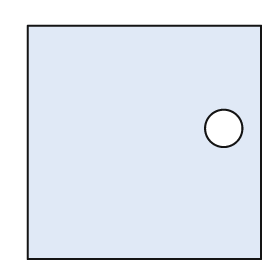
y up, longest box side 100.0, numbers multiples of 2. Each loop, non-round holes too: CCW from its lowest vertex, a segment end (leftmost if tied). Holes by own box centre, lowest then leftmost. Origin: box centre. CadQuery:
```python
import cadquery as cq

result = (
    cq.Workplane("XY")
    .moveTo(-50.0, -50.0)
    .lineTo(50.0, -50.0)
    .lineTo(50.0, 50.0)
    .lineTo(-50.0, 50.0)
    .close()
    .moveTo(34.0, 6.0)
    .circle(8.0)
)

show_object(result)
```